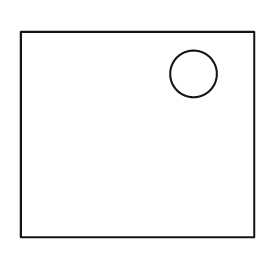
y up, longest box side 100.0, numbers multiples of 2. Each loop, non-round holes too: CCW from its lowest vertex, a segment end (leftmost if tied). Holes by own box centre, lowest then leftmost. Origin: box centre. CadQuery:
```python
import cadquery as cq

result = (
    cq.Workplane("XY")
    .moveTo(-50.0, -44.0)
    .lineTo(50.0, -44.0)
    .lineTo(50.0, 44.0)
    .lineTo(-50.0, 44.0)
    .close()
    .moveTo(24.0, 26.0)
    .circle(10.0)
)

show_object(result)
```